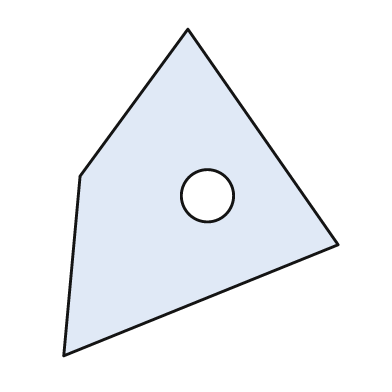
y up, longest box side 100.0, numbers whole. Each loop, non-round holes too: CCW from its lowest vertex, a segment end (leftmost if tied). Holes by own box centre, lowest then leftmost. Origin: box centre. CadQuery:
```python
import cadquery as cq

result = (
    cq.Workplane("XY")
    .moveTo(-42.0, -50.0)
    .lineTo(42.0, -16.0)
    .lineTo(-4.0, 50.0)
    .lineTo(-37.0, 5.0)
    .close()
    .moveTo(2.0, -1.0)
    .circle(8.0)
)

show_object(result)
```